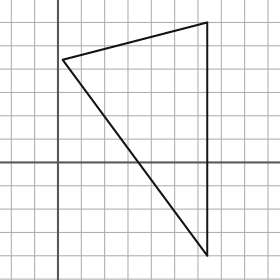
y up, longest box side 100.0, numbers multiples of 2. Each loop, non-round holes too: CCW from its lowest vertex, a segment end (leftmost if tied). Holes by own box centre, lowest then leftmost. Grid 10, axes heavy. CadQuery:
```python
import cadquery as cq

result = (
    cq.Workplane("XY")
    .moveTo(64.0, -40.0)
    .lineTo(64.0, 60.0)
    .lineTo(2.0, 44.0)
    .close()
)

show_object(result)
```